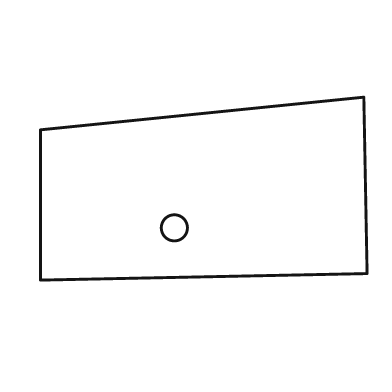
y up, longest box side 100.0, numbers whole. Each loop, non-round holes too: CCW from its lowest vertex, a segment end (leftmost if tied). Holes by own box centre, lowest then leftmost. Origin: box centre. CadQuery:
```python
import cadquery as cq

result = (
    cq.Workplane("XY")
    .moveTo(-50.0, -28.0)
    .lineTo(50.0, -26.0)
    .lineTo(49.0, 28.0)
    .lineTo(-50.0, 18.0)
    .close()
    .moveTo(-9.0, -12.0)
    .circle(4.0)
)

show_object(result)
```